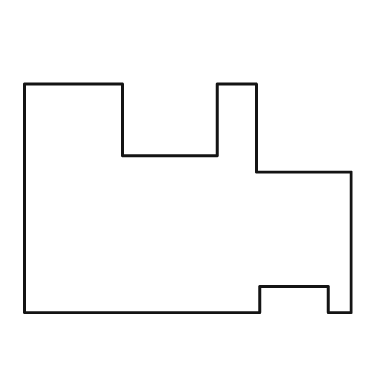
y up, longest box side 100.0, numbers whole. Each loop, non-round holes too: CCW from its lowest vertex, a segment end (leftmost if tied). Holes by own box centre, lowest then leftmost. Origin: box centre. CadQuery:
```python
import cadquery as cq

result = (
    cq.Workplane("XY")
    .moveTo(-50.0, -35.0)
    .lineTo(22.0, -35.0)
    .lineTo(22.0, -27.0)
    .lineTo(43.0, -27.0)
    .lineTo(43.0, -35.0)
    .lineTo(50.0, -35.0)
    .lineTo(50.0, 8.0)
    .lineTo(21.0, 8.0)
    .lineTo(21.0, 35.0)
    .lineTo(9.0, 35.0)
    .lineTo(9.0, 13.0)
    .lineTo(-20.0, 13.0)
    .lineTo(-20.0, 35.0)
    .lineTo(-50.0, 35.0)
    .close()
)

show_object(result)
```